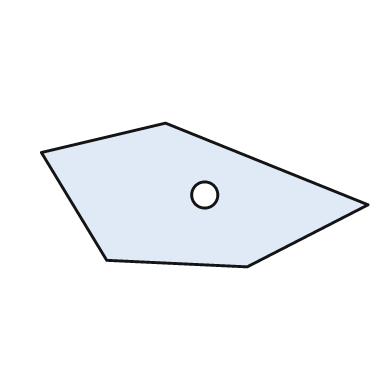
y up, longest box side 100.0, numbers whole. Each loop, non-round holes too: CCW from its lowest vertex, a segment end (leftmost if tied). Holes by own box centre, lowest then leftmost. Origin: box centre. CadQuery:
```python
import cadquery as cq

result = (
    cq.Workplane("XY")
    .moveTo(13.0, -22.0)
    .lineTo(50.0, -3.0)
    .lineTo(-12.0, 22.0)
    .lineTo(-50.0, 13.0)
    .lineTo(-30.0, -20.0)
    .close()
    .moveTo(0.0, 0.0)
    .circle(4.0)
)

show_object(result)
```